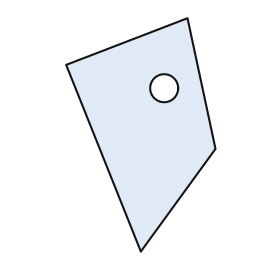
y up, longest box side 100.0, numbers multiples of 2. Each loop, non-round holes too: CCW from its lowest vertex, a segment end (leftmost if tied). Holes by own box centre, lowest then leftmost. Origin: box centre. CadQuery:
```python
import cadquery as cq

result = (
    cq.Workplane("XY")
    .moveTo(0.0, -50.0)
    .lineTo(32.0, -6.0)
    .lineTo(20.0, 50.0)
    .lineTo(-32.0, 30.0)
    .close()
    .moveTo(10.0, 20.0)
    .circle(6.0)
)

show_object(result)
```